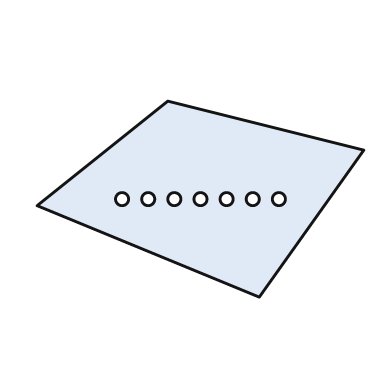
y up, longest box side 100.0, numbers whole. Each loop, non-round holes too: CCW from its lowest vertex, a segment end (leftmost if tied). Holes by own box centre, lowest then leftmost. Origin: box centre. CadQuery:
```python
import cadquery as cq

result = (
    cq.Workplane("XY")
    .moveTo(18.0, -30.0)
    .lineTo(50.0, 15.0)
    .lineTo(-10.0, 30.0)
    .lineTo(-50.0, -2.0)
    .close()
    .moveTo(-24.0, 0.0)
    .circle(2.0)
    .moveTo(-16.0, 0.0)
    .circle(2.0)
    .moveTo(-8.0, 0.0)
    .circle(2.0)
    .moveTo(0.0, 0.0)
    .circle(2.0)
    .moveTo(8.0, 0.0)
    .circle(2.0)
    .moveTo(16.0, 0.0)
    .circle(2.0)
    .moveTo(24.0, 0.0)
    .circle(2.0)
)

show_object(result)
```